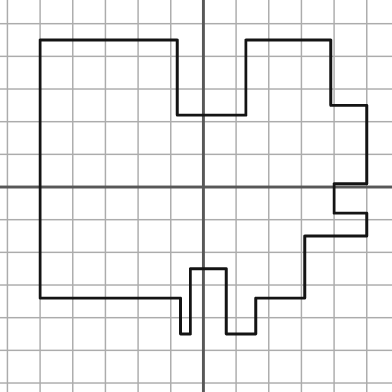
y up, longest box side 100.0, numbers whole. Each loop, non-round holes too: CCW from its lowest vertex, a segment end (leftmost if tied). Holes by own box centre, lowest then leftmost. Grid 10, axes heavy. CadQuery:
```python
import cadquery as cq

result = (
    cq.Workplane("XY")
    .moveTo(-7.0, -45.0)
    .lineTo(-4.0, -45.0)
    .lineTo(-4.0, -25.0)
    .lineTo(7.0, -25.0)
    .lineTo(7.0, -45.0)
    .lineTo(16.0, -45.0)
    .lineTo(16.0, -34.0)
    .lineTo(31.0, -34.0)
    .lineTo(31.0, -15.0)
    .lineTo(50.0, -15.0)
    .lineTo(50.0, -8.0)
    .lineTo(40.0, -8.0)
    .lineTo(40.0, 1.0)
    .lineTo(50.0, 1.0)
    .lineTo(50.0, 25.0)
    .lineTo(39.0, 25.0)
    .lineTo(39.0, 45.0)
    .lineTo(13.0, 45.0)
    .lineTo(13.0, 22.0)
    .lineTo(-8.0, 22.0)
    .lineTo(-8.0, 45.0)
    .lineTo(-50.0, 45.0)
    .lineTo(-50.0, -34.0)
    .lineTo(-7.0, -34.0)
    .close()
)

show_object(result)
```